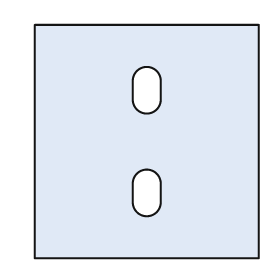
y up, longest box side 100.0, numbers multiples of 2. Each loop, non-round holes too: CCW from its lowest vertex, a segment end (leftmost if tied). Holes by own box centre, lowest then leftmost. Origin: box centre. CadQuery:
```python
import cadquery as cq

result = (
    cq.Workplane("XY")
    .moveTo(-48.0, -50.0)
    .lineTo(48.0, -50.0)
    .lineTo(48.0, 50.0)
    .lineTo(-48.0, 50.0)
    .close()
    .moveTo(-6.0, -26.0)
    .threePointArc((0.0, -32.0), (6.0, -26.0))
    .lineTo(6.0, -18.0)
    .threePointArc((0.0, -12.0), (-6.0, -18.0))
    .close()
    .moveTo(-6.0, 18.0)
    .threePointArc((0.0, 12.0), (6.0, 18.0))
    .lineTo(6.0, 26.0)
    .threePointArc((0.0, 32.0), (-6.0, 26.0))
    .close()
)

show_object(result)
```